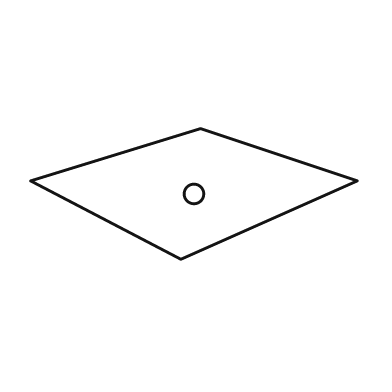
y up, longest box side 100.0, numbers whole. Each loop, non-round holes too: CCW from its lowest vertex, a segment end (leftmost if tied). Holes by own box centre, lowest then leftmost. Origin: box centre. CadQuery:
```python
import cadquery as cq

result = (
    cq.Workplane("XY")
    .moveTo(-4.0, -20.0)
    .lineTo(50.0, 4.0)
    .lineTo(2.0, 20.0)
    .lineTo(-50.0, 4.0)
    .close()
    .moveTo(0.0, 0.0)
    .circle(3.0)
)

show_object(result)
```